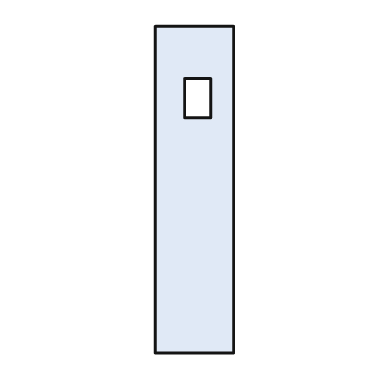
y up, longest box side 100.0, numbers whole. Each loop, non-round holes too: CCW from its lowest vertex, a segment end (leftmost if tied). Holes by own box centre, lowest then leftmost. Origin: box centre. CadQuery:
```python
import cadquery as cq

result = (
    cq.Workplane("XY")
    .moveTo(-12.0, -50.0)
    .lineTo(12.0, -50.0)
    .lineTo(12.0, 50.0)
    .lineTo(-12.0, 50.0)
    .close()
    .moveTo(-3.0, 22.0)
    .lineTo(5.0, 22.0)
    .lineTo(5.0, 34.0)
    .lineTo(-3.0, 34.0)
    .close()
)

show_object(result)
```